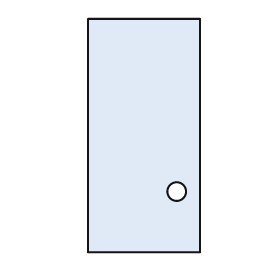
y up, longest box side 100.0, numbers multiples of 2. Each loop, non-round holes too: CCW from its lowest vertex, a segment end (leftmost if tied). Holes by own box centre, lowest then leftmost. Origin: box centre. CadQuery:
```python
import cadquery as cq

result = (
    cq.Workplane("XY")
    .moveTo(-24.0, -50.0)
    .lineTo(24.0, -50.0)
    .lineTo(24.0, 50.0)
    .lineTo(-24.0, 50.0)
    .close()
    .moveTo(14.0, -24.0)
    .circle(4.0)
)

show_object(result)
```